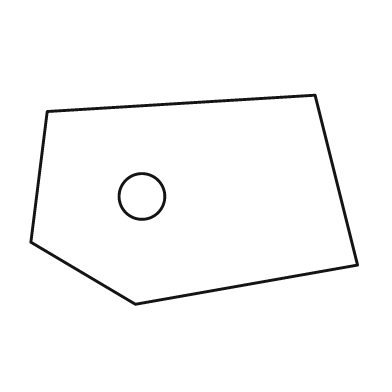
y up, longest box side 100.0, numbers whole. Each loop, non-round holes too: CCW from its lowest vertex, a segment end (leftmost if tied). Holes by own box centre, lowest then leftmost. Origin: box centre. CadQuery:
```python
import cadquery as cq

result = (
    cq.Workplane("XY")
    .moveTo(-18.0, -32.0)
    .lineTo(50.0, -20.0)
    .lineTo(37.0, 32.0)
    .lineTo(-45.0, 27.0)
    .lineTo(-50.0, -13.0)
    .close()
    .moveTo(-16.0, 1.0)
    .circle(7.0)
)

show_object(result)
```